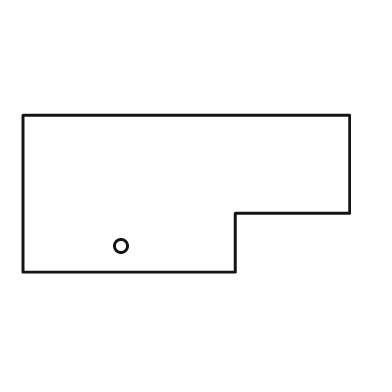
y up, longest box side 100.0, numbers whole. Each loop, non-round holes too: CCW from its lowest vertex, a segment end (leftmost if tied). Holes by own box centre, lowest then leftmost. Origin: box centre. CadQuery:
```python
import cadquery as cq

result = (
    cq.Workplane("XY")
    .moveTo(-50.0, -24.0)
    .lineTo(15.0, -24.0)
    .lineTo(15.0, -6.0)
    .lineTo(50.0, -6.0)
    .lineTo(50.0, 24.0)
    .lineTo(-50.0, 24.0)
    .close()
    .moveTo(-20.0, -16.0)
    .circle(2.0)
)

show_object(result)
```